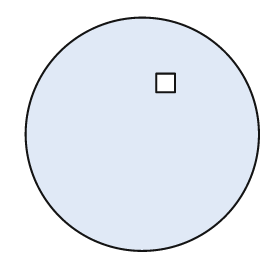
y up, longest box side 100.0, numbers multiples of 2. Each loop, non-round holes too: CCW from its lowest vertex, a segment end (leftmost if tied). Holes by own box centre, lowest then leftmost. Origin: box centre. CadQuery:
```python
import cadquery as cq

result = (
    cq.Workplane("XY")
    .moveTo(0.0, 0.0)
    .circle(50.0)
    .moveTo(6.0, 18.0)
    .lineTo(14.0, 18.0)
    .lineTo(14.0, 26.0)
    .lineTo(6.0, 26.0)
    .close()
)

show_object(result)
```